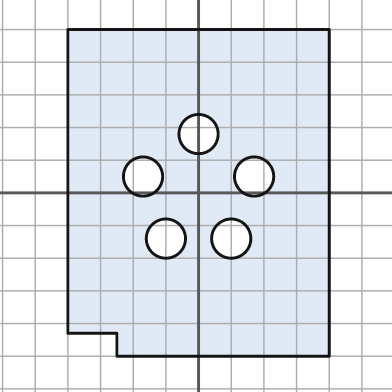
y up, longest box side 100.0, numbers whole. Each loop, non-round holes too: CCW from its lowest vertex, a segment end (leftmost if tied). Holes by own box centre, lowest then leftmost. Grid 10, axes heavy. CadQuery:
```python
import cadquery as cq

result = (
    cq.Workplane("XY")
    .moveTo(-25.0, -50.0)
    .lineTo(40.0, -50.0)
    .lineTo(40.0, 50.0)
    .lineTo(-40.0, 50.0)
    .lineTo(-40.0, -43.0)
    .lineTo(-25.0, -43.0)
    .close()
    .moveTo(-10.0, -14.0)
    .circle(6.0)
    .moveTo(10.0, -14.0)
    .circle(6.0)
    .moveTo(-17.0, 5.0)
    .circle(6.0)
    .moveTo(17.0, 5.0)
    .circle(6.0)
    .moveTo(0.0, 18.0)
    .circle(6.0)
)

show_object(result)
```